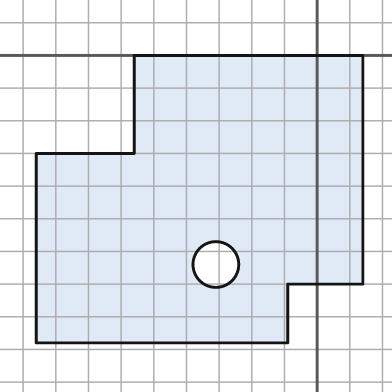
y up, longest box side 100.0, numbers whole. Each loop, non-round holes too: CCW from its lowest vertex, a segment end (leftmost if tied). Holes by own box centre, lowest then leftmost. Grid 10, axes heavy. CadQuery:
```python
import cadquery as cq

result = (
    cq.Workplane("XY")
    .moveTo(-86.0, -88.0)
    .lineTo(-9.0, -88.0)
    .lineTo(-9.0, -70.0)
    .lineTo(14.0, -70.0)
    .lineTo(14.0, 0.0)
    .lineTo(-56.0, 0.0)
    .lineTo(-56.0, -30.0)
    .lineTo(-86.0, -30.0)
    .close()
    .moveTo(-31.0, -64.0)
    .circle(7.0)
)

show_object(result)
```